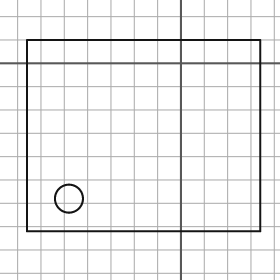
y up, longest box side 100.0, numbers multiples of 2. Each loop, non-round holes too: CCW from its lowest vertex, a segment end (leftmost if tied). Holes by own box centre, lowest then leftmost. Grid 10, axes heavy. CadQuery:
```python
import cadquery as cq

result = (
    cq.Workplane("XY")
    .moveTo(-66.0, -72.0)
    .lineTo(34.0, -72.0)
    .lineTo(34.0, 10.0)
    .lineTo(-66.0, 10.0)
    .close()
    .moveTo(-48.0, -58.0)
    .circle(6.0)
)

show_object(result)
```